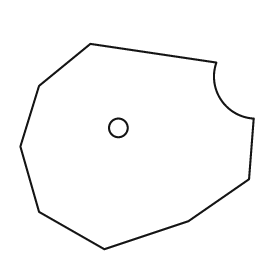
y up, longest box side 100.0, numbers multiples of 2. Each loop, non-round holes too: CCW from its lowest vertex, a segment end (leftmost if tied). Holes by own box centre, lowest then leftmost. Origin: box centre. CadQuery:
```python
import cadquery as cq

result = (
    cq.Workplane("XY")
    .moveTo(-14.0, -44.0)
    .lineTo(22.0, -32.0)
    .lineTo(48.0, -14.0)
    .lineTo(50.0, 12.0)
    .threePointArc((36.0, 20.0), (34.0, 36.0))
    .lineTo(-20.0, 44.0)
    .lineTo(-42.0, 26.0)
    .lineTo(-50.0, 0.0)
    .lineTo(-42.0, -28.0)
    .close()
    .moveTo(-8.0, 8.0)
    .circle(4.0)
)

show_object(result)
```